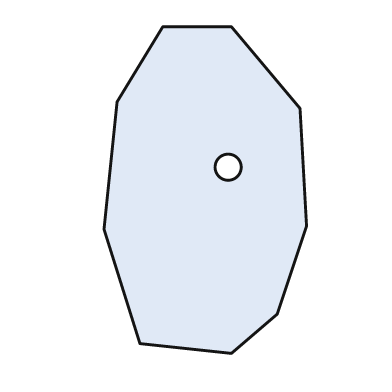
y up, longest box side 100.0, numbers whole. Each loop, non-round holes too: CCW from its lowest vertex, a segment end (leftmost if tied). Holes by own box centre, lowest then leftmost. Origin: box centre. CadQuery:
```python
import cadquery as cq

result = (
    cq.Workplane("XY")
    .moveTo(8.0, -50.0)
    .lineTo(22.0, -38.0)
    .lineTo(31.0, -11.0)
    .lineTo(29.0, 25.0)
    .lineTo(8.0, 50.0)
    .lineTo(-13.0, 50.0)
    .lineTo(-27.0, 27.0)
    .lineTo(-31.0, -12.0)
    .lineTo(-20.0, -47.0)
    .close()
    .moveTo(7.0, 7.0)
    .circle(4.0)
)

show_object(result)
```